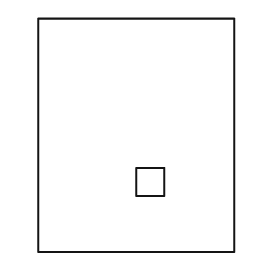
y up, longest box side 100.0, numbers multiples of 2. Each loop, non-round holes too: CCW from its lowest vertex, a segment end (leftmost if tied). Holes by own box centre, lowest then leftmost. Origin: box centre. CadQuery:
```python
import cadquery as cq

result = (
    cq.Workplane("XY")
    .moveTo(-42.0, -50.0)
    .lineTo(42.0, -50.0)
    .lineTo(42.0, 50.0)
    .lineTo(-42.0, 50.0)
    .close()
    .moveTo(0.0, -26.0)
    .lineTo(12.0, -26.0)
    .lineTo(12.0, -14.0)
    .lineTo(0.0, -14.0)
    .close()
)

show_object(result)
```